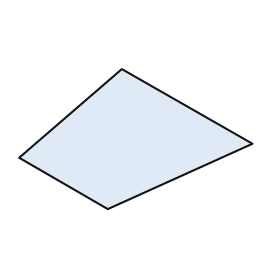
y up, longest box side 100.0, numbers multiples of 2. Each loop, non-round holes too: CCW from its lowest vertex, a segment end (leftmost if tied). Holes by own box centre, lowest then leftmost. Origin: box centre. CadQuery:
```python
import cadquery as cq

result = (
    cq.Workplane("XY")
    .moveTo(-12.0, -30.0)
    .lineTo(50.0, -2.0)
    .lineTo(-6.0, 30.0)
    .lineTo(-50.0, -8.0)
    .close()
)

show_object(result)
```